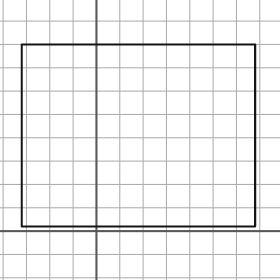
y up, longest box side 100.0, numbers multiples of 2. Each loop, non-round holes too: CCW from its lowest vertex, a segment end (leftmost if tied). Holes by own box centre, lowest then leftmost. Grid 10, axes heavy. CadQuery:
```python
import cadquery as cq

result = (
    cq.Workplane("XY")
    .moveTo(-32.0, 2.0)
    .lineTo(68.0, 2.0)
    .lineTo(68.0, 80.0)
    .lineTo(-32.0, 80.0)
    .close()
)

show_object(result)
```